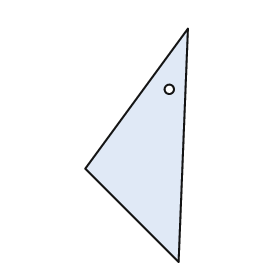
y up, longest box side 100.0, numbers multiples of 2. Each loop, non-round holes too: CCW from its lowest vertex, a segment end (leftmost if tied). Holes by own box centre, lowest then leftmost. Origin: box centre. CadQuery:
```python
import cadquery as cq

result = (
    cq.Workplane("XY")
    .moveTo(18.0, -50.0)
    .lineTo(22.0, 50.0)
    .lineTo(-22.0, -10.0)
    .close()
    .moveTo(14.0, 24.0)
    .circle(2.0)
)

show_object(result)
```